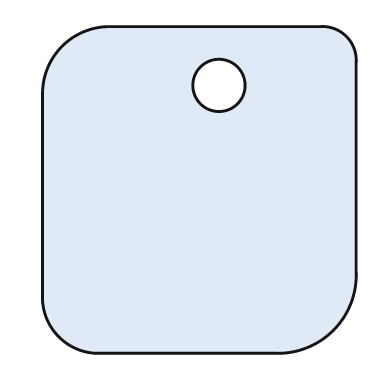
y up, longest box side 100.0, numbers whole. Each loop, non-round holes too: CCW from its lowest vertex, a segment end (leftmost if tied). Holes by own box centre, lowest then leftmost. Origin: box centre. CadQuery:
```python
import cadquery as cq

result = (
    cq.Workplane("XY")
    .moveTo(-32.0, -50.0)
    .lineTo(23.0, -50.0)
    .threePointArc((41.0, -43.0), (48.0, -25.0))
    .lineTo(48.0, 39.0)
    .threePointArc((45.0, 47.0), (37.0, 50.0))
    .lineTo(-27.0, 50.0)
    .threePointArc((-42.0, 44.0), (-48.0, 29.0))
    .lineTo(-48.0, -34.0)
    .threePointArc((-43.0, -45.0), (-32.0, -50.0))
    .close()
    .moveTo(6.0, 32.0)
    .circle(8.0)
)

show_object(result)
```